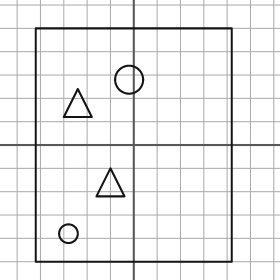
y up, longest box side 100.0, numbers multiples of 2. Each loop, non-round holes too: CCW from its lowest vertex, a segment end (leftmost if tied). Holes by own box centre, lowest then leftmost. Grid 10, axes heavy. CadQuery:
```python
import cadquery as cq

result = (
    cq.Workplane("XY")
    .moveTo(-42.0, -50.0)
    .lineTo(42.0, -50.0)
    .lineTo(42.0, 50.0)
    .lineTo(-42.0, 50.0)
    .close()
    .moveTo(-28.0, -38.0)
    .circle(4.0)
    .moveTo(-16.0, -22.0)
    .lineTo(-4.0, -22.0)
    .lineTo(-10.0, -10.0)
    .close()
    .moveTo(-30.0, 12.0)
    .lineTo(-18.0, 12.0)
    .lineTo(-24.0, 24.0)
    .close()
    .moveTo(-2.0, 28.0)
    .circle(6.0)
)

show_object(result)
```